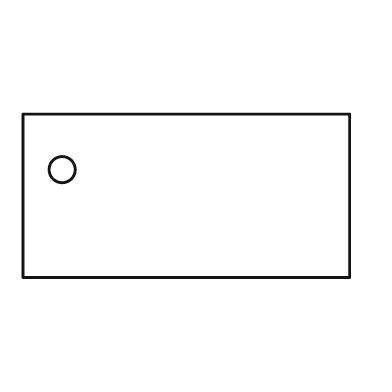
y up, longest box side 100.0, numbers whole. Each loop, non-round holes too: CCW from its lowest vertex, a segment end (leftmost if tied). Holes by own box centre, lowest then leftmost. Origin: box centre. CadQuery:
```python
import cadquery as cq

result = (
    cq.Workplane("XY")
    .moveTo(-50.0, -25.0)
    .lineTo(50.0, -25.0)
    .lineTo(50.0, 25.0)
    .lineTo(-50.0, 25.0)
    .close()
    .moveTo(-38.0, 8.0)
    .circle(4.0)
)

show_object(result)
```